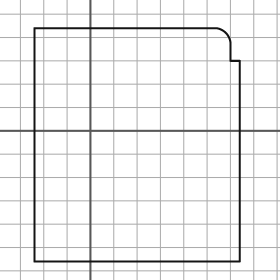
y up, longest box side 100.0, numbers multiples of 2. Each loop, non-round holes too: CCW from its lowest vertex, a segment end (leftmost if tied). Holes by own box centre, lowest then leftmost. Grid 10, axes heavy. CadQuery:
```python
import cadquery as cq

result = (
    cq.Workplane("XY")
    .moveTo(-24.0, -56.0)
    .lineTo(64.0, -56.0)
    .lineTo(64.0, 30.0)
    .lineTo(60.0, 30.0)
    .lineTo(60.0, 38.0)
    .threePointArc((58.0, 42.0), (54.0, 44.0))
    .lineTo(-24.0, 44.0)
    .close()
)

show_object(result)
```